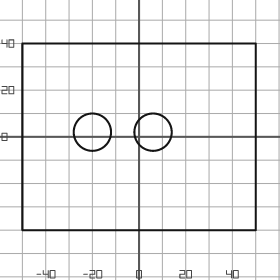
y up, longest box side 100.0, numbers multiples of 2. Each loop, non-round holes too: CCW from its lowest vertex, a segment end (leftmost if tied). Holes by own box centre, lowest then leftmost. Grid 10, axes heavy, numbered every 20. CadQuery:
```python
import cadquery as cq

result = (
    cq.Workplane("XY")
    .moveTo(-50.0, -40.0)
    .lineTo(50.0, -40.0)
    .lineTo(50.0, 40.0)
    .lineTo(-50.0, 40.0)
    .close()
    .moveTo(-20.0, 2.0)
    .circle(8.0)
    .moveTo(6.0, 2.0)
    .circle(8.0)
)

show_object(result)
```